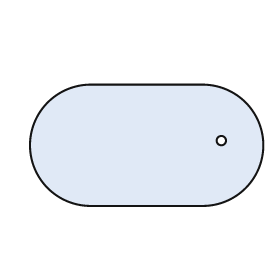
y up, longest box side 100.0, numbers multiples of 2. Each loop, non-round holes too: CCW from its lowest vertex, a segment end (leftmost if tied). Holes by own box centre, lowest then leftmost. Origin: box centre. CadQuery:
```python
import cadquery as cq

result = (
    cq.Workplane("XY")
    .moveTo(-24.0, -26.0)
    .lineTo(24.0, -26.0)
    .threePointArc((50.0, 0.0), (24.0, 26.0))
    .lineTo(-24.0, 26.0)
    .threePointArc((-50.0, 0.0), (-24.0, -26.0))
    .close()
    .moveTo(32.0, 2.0)
    .circle(2.0)
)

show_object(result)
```